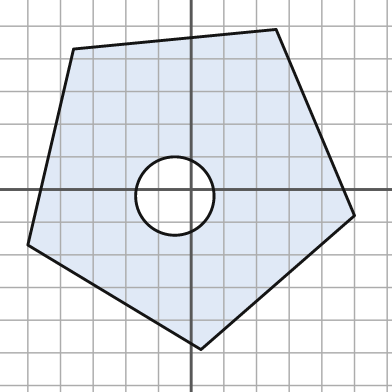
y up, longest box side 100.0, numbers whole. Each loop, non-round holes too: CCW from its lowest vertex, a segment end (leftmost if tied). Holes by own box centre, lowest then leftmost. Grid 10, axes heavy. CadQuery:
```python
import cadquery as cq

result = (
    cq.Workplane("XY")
    .moveTo(3.0, -49.0)
    .lineTo(50.0, -8.0)
    .lineTo(26.0, 49.0)
    .lineTo(-36.0, 43.0)
    .lineTo(-50.0, -17.0)
    .close()
    .moveTo(-5.0, -2.0)
    .circle(12.0)
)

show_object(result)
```